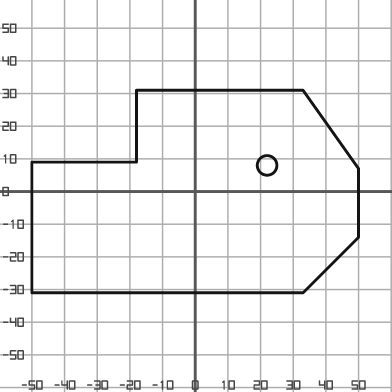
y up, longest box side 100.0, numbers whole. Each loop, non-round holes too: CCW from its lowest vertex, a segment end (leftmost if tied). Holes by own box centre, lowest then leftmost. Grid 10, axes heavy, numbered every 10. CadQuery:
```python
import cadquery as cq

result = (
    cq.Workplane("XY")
    .moveTo(-50.0, -31.0)
    .lineTo(33.0, -31.0)
    .lineTo(50.0, -14.0)
    .lineTo(50.0, 7.0)
    .lineTo(33.0, 31.0)
    .lineTo(-18.0, 31.0)
    .lineTo(-18.0, 9.0)
    .lineTo(-50.0, 9.0)
    .close()
    .moveTo(22.0, 8.0)
    .circle(3.0)
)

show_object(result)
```